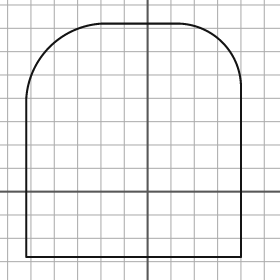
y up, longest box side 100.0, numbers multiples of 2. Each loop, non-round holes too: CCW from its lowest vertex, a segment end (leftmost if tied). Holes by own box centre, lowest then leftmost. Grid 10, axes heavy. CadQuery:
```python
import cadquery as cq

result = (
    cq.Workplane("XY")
    .moveTo(-52.0, -28.0)
    .lineTo(40.0, -28.0)
    .lineTo(40.0, 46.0)
    .threePointArc((32.0, 64.0), (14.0, 72.0))
    .lineTo(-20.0, 72.0)
    .threePointArc((-42.0, 62.0), (-52.0, 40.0))
    .close()
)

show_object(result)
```